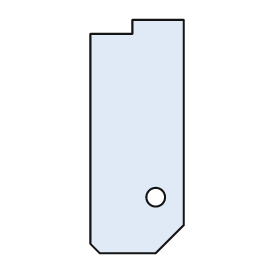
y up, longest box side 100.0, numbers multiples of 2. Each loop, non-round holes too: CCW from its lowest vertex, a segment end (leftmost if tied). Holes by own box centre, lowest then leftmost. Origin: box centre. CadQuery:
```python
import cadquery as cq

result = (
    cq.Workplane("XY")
    .moveTo(-16.0, -50.0)
    .lineTo(8.0, -50.0)
    .lineTo(20.0, -38.0)
    .lineTo(20.0, 50.0)
    .lineTo(-2.0, 50.0)
    .lineTo(-2.0, 44.0)
    .lineTo(-20.0, 44.0)
    .lineTo(-20.0, -46.0)
    .close()
    .moveTo(8.0, -26.0)
    .circle(4.0)
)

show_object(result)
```